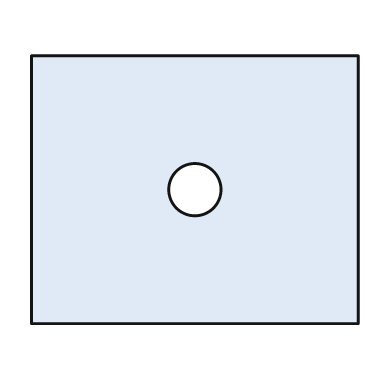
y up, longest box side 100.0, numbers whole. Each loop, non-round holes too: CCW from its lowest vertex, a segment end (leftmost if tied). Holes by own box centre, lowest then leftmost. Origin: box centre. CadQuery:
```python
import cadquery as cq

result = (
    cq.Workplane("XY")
    .moveTo(-50.0, -41.0)
    .lineTo(50.0, -41.0)
    .lineTo(50.0, 41.0)
    .lineTo(-50.0, 41.0)
    .close()
    .moveTo(0.0, 0.0)
    .circle(8.0)
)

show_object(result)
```